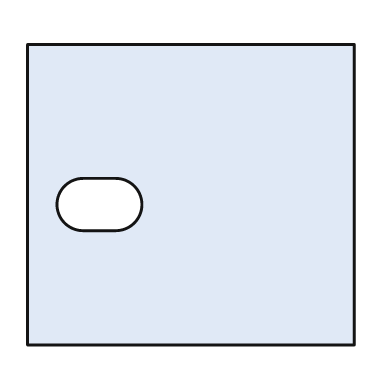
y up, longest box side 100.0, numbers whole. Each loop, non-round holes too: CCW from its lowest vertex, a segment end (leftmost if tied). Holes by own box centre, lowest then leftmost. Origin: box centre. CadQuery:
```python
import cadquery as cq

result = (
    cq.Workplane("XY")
    .moveTo(-50.0, -46.0)
    .lineTo(50.0, -46.0)
    .lineTo(50.0, 46.0)
    .lineTo(-50.0, 46.0)
    .close()
    .moveTo(-33.0, -11.0)
    .lineTo(-23.0, -11.0)
    .threePointArc((-15.0, -3.0), (-23.0, 5.0))
    .lineTo(-33.0, 5.0)
    .threePointArc((-41.0, -3.0), (-33.0, -11.0))
    .close()
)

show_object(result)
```